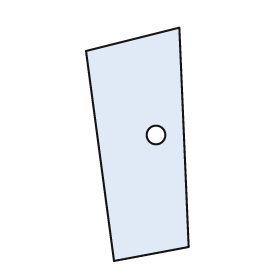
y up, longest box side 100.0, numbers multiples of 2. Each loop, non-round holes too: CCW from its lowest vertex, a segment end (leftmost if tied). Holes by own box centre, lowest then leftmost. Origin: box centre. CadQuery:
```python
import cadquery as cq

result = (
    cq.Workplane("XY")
    .moveTo(-10.0, -50.0)
    .lineTo(22.0, -44.0)
    .lineTo(18.0, 50.0)
    .lineTo(-22.0, 40.0)
    .close()
    .moveTo(8.0, 4.0)
    .circle(4.0)
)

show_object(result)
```